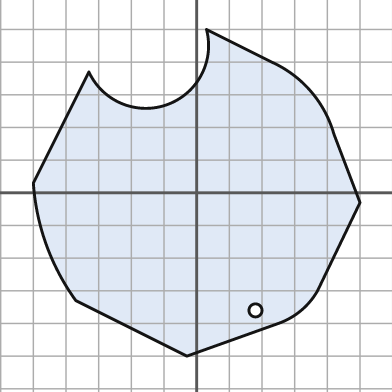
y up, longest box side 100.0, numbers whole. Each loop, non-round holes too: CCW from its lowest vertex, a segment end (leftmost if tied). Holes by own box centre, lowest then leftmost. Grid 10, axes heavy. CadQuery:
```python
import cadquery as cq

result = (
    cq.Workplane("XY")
    .moveTo(-3.0, -50.0)
    .lineTo(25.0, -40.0)
    .threePointArc((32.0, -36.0), (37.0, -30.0))
    .lineTo(50.0, -3.0)
    .lineTo(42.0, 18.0)
    .threePointArc((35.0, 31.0), (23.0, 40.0))
    .lineTo(3.0, 50.0)
    .threePointArc((-9.0, 27.0), (-33.0, 37.0))
    .lineTo(-50.0, 3.0)
    .threePointArc((-46.0, -16.0), (-37.0, -33.0))
    .close()
    .moveTo(18.0, -36.0)
    .circle(2.0)
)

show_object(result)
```